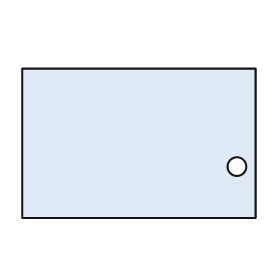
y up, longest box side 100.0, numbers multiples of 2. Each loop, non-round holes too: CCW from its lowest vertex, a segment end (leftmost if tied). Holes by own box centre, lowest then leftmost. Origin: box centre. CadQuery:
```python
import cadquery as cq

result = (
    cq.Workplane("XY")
    .moveTo(-50.0, -32.0)
    .lineTo(50.0, -32.0)
    .lineTo(50.0, 32.0)
    .lineTo(-50.0, 32.0)
    .close()
    .moveTo(42.0, -10.0)
    .circle(4.0)
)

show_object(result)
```